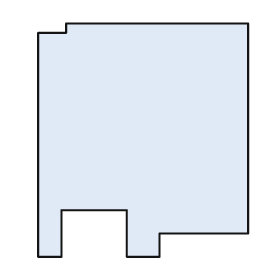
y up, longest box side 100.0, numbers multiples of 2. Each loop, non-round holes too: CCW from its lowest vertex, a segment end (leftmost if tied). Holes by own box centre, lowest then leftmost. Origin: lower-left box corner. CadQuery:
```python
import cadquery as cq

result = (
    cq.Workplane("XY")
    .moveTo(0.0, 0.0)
    .lineTo(10.0, 0.0)
    .lineTo(10.0, 20.0)
    .lineTo(38.0, 20.0)
    .lineTo(38.0, 0.0)
    .lineTo(52.0, 0.0)
    .lineTo(52.0, 10.0)
    .lineTo(90.0, 10.0)
    .lineTo(90.0, 100.0)
    .lineTo(12.0, 100.0)
    .lineTo(12.0, 96.0)
    .lineTo(0.0, 96.0)
    .close()
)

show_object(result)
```